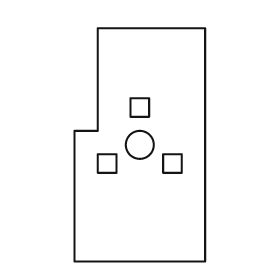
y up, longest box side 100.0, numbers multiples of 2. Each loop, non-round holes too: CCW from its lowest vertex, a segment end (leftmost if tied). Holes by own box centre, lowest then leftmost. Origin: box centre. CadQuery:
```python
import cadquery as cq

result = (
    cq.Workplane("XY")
    .moveTo(-28.0, -50.0)
    .lineTo(28.0, -50.0)
    .lineTo(28.0, 50.0)
    .lineTo(-18.0, 50.0)
    .lineTo(-18.0, 6.0)
    .lineTo(-28.0, 6.0)
    .close()
    .moveTo(-18.0, -12.0)
    .lineTo(-10.0, -12.0)
    .lineTo(-10.0, -4.0)
    .lineTo(-18.0, -4.0)
    .close()
    .moveTo(10.0, -12.0)
    .lineTo(18.0, -12.0)
    .lineTo(18.0, -4.0)
    .lineTo(10.0, -4.0)
    .close()
    .moveTo(0.0, 0.0)
    .circle(6.0)
    .moveTo(-4.0, 12.0)
    .lineTo(4.0, 12.0)
    .lineTo(4.0, 20.0)
    .lineTo(-4.0, 20.0)
    .close()
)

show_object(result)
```